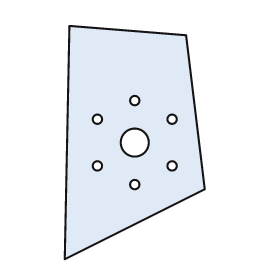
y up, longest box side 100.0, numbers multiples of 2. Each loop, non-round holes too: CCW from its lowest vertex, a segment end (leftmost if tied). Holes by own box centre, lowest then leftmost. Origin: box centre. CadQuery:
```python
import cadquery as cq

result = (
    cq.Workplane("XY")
    .moveTo(-30.0, -50.0)
    .lineTo(30.0, -20.0)
    .lineTo(22.0, 46.0)
    .lineTo(-28.0, 50.0)
    .close()
    .moveTo(0.0, -18.0)
    .circle(2.0)
    .moveTo(-16.0, -10.0)
    .circle(2.0)
    .moveTo(16.0, -10.0)
    .circle(2.0)
    .moveTo(0.0, 0.0)
    .circle(6.0)
    .moveTo(-16.0, 10.0)
    .circle(2.0)
    .moveTo(16.0, 10.0)
    .circle(2.0)
    .moveTo(0.0, 18.0)
    .circle(2.0)
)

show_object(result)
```